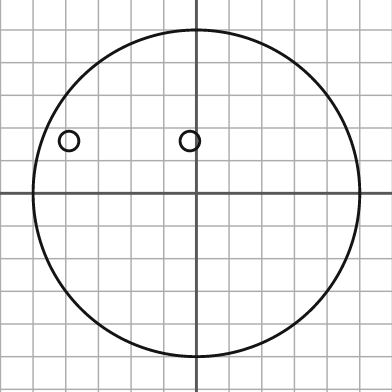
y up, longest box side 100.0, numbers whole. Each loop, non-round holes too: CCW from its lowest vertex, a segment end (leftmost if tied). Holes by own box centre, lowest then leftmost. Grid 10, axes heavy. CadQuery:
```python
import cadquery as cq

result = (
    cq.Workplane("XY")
    .moveTo(0.0, 0.0)
    .circle(50.0)
    .moveTo(-39.0, 16.0)
    .circle(3.0)
    .moveTo(-2.0, 16.0)
    .circle(3.0)
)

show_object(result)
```